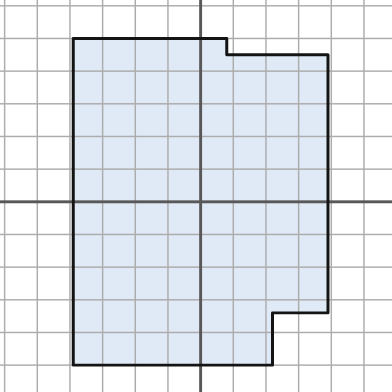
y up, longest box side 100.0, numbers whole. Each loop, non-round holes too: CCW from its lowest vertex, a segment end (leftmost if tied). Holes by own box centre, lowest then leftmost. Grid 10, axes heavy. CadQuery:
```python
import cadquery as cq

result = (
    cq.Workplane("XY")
    .moveTo(-39.0, -50.0)
    .lineTo(22.0, -50.0)
    .lineTo(22.0, -34.0)
    .lineTo(39.0, -34.0)
    .lineTo(39.0, 45.0)
    .lineTo(8.0, 45.0)
    .lineTo(8.0, 50.0)
    .lineTo(-39.0, 50.0)
    .close()
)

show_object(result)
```